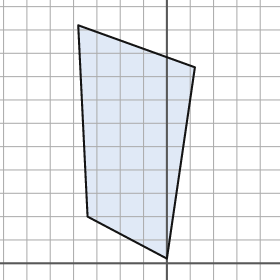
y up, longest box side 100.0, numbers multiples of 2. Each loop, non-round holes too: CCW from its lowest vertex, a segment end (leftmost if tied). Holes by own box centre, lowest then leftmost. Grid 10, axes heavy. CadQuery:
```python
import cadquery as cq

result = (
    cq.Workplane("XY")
    .moveTo(0.0, 2.0)
    .lineTo(12.0, 84.0)
    .lineTo(-38.0, 102.0)
    .lineTo(-34.0, 20.0)
    .close()
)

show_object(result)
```